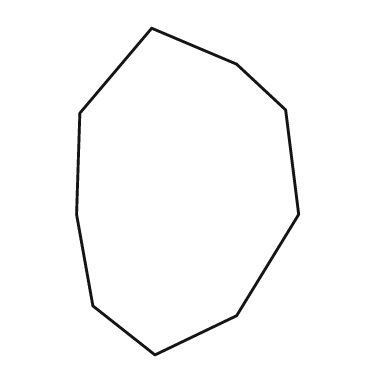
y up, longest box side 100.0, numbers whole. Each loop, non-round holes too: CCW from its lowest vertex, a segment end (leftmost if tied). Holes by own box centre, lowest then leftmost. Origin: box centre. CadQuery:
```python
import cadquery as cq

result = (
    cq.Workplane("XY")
    .moveTo(-10.0, -50.0)
    .lineTo(15.0, -38.0)
    .lineTo(34.0, -7.0)
    .lineTo(30.0, 25.0)
    .lineTo(15.0, 39.0)
    .lineTo(-11.0, 50.0)
    .lineTo(-33.0, 24.0)
    .lineTo(-34.0, -7.0)
    .lineTo(-29.0, -35.0)
    .close()
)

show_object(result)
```